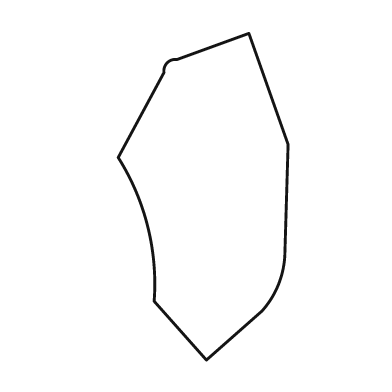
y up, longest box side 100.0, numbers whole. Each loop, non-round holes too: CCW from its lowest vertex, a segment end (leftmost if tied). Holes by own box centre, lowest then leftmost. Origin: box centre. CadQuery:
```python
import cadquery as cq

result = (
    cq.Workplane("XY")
    .moveTo(1.0, -50.0)
    .lineTo(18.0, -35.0)
    .threePointArc((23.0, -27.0), (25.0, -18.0))
    .lineTo(26.0, 16.0)
    .lineTo(14.0, 50.0)
    .lineTo(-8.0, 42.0)
    .threePointArc((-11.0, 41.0), (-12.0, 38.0))
    .lineTo(-26.0, 12.0)
    .threePointArc((-17.0, -9.0), (-15.0, -32.0))
    .close()
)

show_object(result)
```